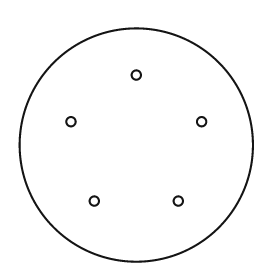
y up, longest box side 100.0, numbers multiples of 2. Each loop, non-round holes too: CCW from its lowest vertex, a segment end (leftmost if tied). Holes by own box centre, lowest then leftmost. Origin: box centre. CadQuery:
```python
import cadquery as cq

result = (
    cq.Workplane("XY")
    .moveTo(0.0, 0.0)
    .circle(50.0)
    .moveTo(-18.0, -24.0)
    .circle(2.0)
    .moveTo(18.0, -24.0)
    .circle(2.0)
    .moveTo(-28.0, 10.0)
    .circle(2.0)
    .moveTo(28.0, 10.0)
    .circle(2.0)
    .moveTo(0.0, 30.0)
    .circle(2.0)
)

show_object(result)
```